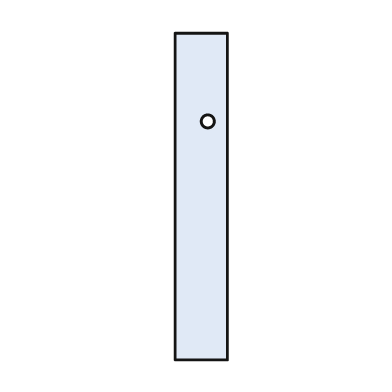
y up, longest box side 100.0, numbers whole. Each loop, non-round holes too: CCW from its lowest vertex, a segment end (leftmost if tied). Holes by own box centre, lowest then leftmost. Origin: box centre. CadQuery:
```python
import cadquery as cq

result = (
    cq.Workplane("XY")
    .moveTo(-8.0, -50.0)
    .lineTo(8.0, -50.0)
    .lineTo(8.0, 50.0)
    .lineTo(-8.0, 50.0)
    .close()
    .moveTo(2.0, 23.0)
    .circle(2.0)
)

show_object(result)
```